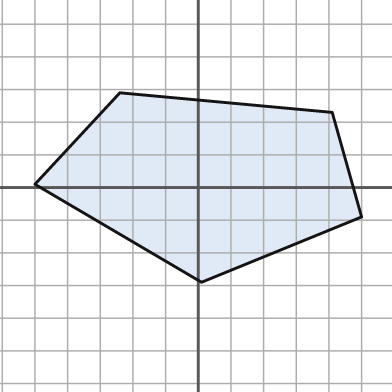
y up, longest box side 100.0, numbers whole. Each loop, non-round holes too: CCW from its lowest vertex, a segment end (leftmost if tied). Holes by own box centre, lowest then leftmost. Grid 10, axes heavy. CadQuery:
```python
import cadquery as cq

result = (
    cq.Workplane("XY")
    .moveTo(1.0, -29.0)
    .lineTo(50.0, -9.0)
    .lineTo(41.0, 23.0)
    .lineTo(-24.0, 29.0)
    .lineTo(-50.0, 1.0)
    .close()
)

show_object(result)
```